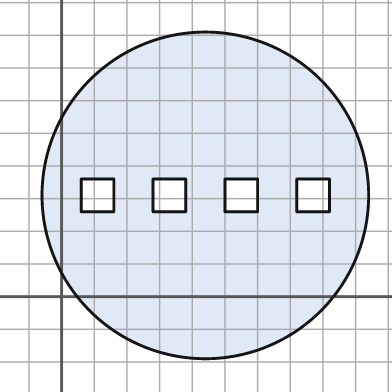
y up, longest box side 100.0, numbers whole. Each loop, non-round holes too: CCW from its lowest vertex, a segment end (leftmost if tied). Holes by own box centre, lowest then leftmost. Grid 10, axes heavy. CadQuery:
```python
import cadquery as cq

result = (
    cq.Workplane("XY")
    .moveTo(44.0, 31.0)
    .circle(50.0)
    .moveTo(6.0, 26.0)
    .lineTo(16.0, 26.0)
    .lineTo(16.0, 36.0)
    .lineTo(6.0, 36.0)
    .close()
    .moveTo(28.0, 26.0)
    .lineTo(38.0, 26.0)
    .lineTo(38.0, 36.0)
    .lineTo(28.0, 36.0)
    .close()
    .moveTo(50.0, 26.0)
    .lineTo(60.0, 26.0)
    .lineTo(60.0, 36.0)
    .lineTo(50.0, 36.0)
    .close()
    .moveTo(72.0, 26.0)
    .lineTo(82.0, 26.0)
    .lineTo(82.0, 36.0)
    .lineTo(72.0, 36.0)
    .close()
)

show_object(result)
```